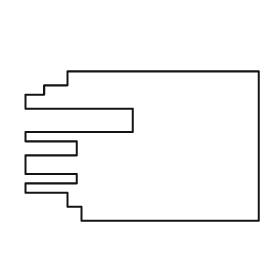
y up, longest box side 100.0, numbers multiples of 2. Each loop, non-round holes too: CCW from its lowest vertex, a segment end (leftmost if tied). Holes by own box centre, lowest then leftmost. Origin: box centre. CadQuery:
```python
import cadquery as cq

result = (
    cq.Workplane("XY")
    .moveTo(-26.0, -32.0)
    .lineTo(50.0, -32.0)
    .lineTo(50.0, 32.0)
    .lineTo(-32.0, 32.0)
    .lineTo(-32.0, 26.0)
    .lineTo(-42.0, 26.0)
    .lineTo(-42.0, 22.0)
    .lineTo(-50.0, 22.0)
    .lineTo(-50.0, 16.0)
    .lineTo(-4.0, 16.0)
    .lineTo(-4.0, 6.0)
    .lineTo(-50.0, 6.0)
    .lineTo(-50.0, 2.0)
    .lineTo(-28.0, 2.0)
    .lineTo(-28.0, -4.0)
    .lineTo(-50.0, -4.0)
    .lineTo(-50.0, -12.0)
    .lineTo(-28.0, -12.0)
    .lineTo(-28.0, -16.0)
    .lineTo(-50.0, -16.0)
    .lineTo(-50.0, -20.0)
    .lineTo(-32.0, -20.0)
    .lineTo(-32.0, -26.0)
    .lineTo(-26.0, -26.0)
    .close()
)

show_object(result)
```